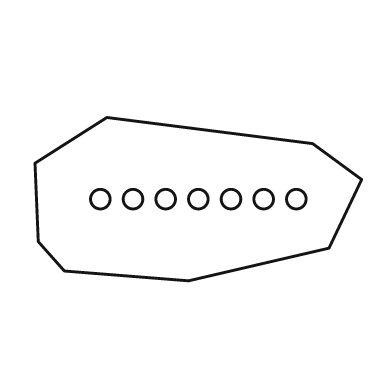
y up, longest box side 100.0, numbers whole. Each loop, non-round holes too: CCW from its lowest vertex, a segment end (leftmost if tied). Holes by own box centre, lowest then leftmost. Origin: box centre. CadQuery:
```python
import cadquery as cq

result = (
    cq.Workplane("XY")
    .moveTo(-3.0, -25.0)
    .lineTo(40.0, -15.0)
    .lineTo(50.0, 6.0)
    .lineTo(35.0, 17.0)
    .lineTo(-28.0, 25.0)
    .lineTo(-50.0, 11.0)
    .lineTo(-49.0, -13.0)
    .lineTo(-41.0, -22.0)
    .close()
    .moveTo(-30.0, 0.0)
    .circle(3.0)
    .moveTo(-20.0, 0.0)
    .circle(3.0)
    .moveTo(-10.0, 0.0)
    .circle(3.0)
    .moveTo(0.0, 0.0)
    .circle(3.0)
    .moveTo(10.0, 0.0)
    .circle(3.0)
    .moveTo(20.0, 0.0)
    .circle(3.0)
    .moveTo(30.0, 0.0)
    .circle(3.0)
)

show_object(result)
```